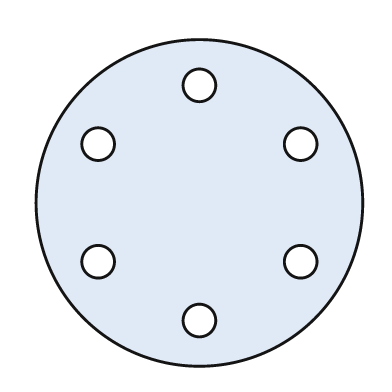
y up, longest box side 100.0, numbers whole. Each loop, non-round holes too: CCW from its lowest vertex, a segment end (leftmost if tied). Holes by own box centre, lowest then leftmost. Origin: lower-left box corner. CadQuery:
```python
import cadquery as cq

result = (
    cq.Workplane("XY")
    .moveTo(50.0, 50.0)
    .circle(50.0)
    .moveTo(50.0, 14.0)
    .circle(5.0)
    .moveTo(19.0, 32.0)
    .circle(5.0)
    .moveTo(81.0, 32.0)
    .circle(5.0)
    .moveTo(19.0, 68.0)
    .circle(5.0)
    .moveTo(81.0, 68.0)
    .circle(5.0)
    .moveTo(50.0, 86.0)
    .circle(5.0)
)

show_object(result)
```